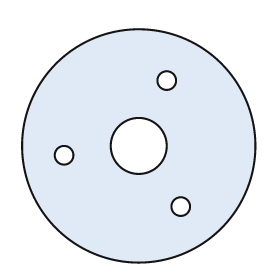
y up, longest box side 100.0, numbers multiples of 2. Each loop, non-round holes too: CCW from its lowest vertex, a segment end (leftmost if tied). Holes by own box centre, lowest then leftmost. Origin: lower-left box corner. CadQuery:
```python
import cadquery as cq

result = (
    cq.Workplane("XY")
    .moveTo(50.0, 50.0)
    .circle(50.0)
    .moveTo(68.0, 24.0)
    .circle(4.0)
    .moveTo(18.0, 46.0)
    .circle(4.0)
    .moveTo(50.0, 50.0)
    .circle(12.0)
    .moveTo(62.0, 78.0)
    .circle(4.0)
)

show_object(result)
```